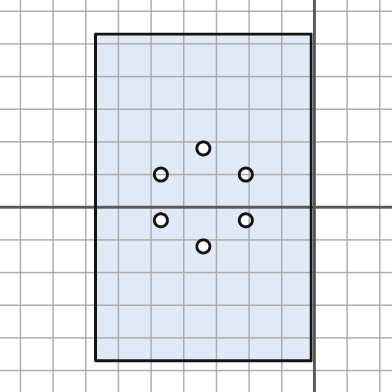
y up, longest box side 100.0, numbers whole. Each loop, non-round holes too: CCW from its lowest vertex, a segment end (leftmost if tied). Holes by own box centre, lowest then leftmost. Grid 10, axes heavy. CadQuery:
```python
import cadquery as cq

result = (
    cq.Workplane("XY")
    .moveTo(-67.0, -47.0)
    .lineTo(-1.0, -47.0)
    .lineTo(-1.0, 53.0)
    .lineTo(-67.0, 53.0)
    .close()
    .moveTo(-34.0, -12.0)
    .circle(2.0)
    .moveTo(-47.0, -4.0)
    .circle(2.0)
    .moveTo(-21.0, -4.0)
    .circle(2.0)
    .moveTo(-47.0, 10.0)
    .circle(2.0)
    .moveTo(-21.0, 10.0)
    .circle(2.0)
    .moveTo(-34.0, 18.0)
    .circle(2.0)
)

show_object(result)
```